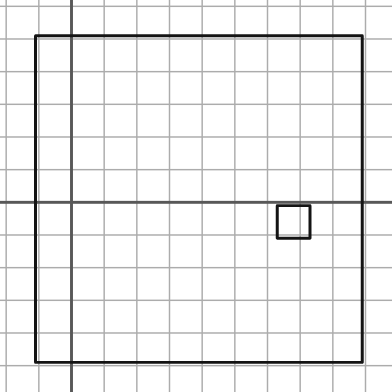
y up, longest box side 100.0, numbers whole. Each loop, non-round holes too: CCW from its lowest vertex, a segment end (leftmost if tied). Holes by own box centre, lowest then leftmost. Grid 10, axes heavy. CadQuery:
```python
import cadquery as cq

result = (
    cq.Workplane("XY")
    .moveTo(-11.0, -49.0)
    .lineTo(89.0, -49.0)
    .lineTo(89.0, 51.0)
    .lineTo(-11.0, 51.0)
    .close()
    .moveTo(63.0, -11.0)
    .lineTo(73.0, -11.0)
    .lineTo(73.0, -1.0)
    .lineTo(63.0, -1.0)
    .close()
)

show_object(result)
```